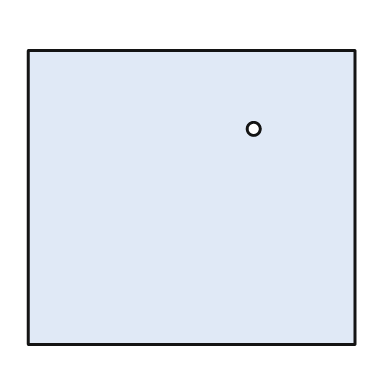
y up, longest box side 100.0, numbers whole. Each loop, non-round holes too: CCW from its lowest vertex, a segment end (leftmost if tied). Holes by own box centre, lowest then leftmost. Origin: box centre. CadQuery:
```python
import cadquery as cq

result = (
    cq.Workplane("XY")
    .moveTo(-50.0, -45.0)
    .lineTo(50.0, -45.0)
    .lineTo(50.0, 45.0)
    .lineTo(-50.0, 45.0)
    .close()
    .moveTo(19.0, 21.0)
    .circle(2.0)
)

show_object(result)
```